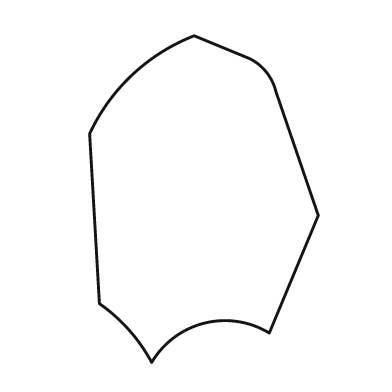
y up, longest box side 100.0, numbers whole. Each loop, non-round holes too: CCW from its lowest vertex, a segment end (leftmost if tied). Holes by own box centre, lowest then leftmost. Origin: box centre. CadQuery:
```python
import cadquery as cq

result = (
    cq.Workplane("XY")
    .moveTo(-16.0, -50.0)
    .threePointArc((0.0, -38.0), (20.0, -41.0))
    .lineTo(35.0, -5.0)
    .lineTo(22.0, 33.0)
    .threePointArc((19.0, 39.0), (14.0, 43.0))
    .lineTo(-3.0, 50.0)
    .threePointArc((-22.0, 38.0), (-35.0, 20.0))
    .lineTo(-32.0, -32.0)
    .threePointArc((-23.0, -40.0), (-16.0, -50.0))
    .close()
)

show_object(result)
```